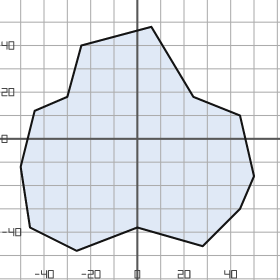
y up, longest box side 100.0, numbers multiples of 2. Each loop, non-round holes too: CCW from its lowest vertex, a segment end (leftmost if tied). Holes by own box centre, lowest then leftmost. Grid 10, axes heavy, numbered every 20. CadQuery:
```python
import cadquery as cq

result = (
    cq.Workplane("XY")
    .moveTo(-26.0, -48.0)
    .lineTo(0.0, -38.0)
    .lineTo(28.0, -46.0)
    .lineTo(44.0, -30.0)
    .lineTo(50.0, -16.0)
    .lineTo(44.0, 10.0)
    .lineTo(24.0, 18.0)
    .lineTo(6.0, 48.0)
    .lineTo(-24.0, 40.0)
    .lineTo(-30.0, 18.0)
    .lineTo(-44.0, 12.0)
    .lineTo(-50.0, -12.0)
    .lineTo(-46.0, -38.0)
    .close()
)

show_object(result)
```